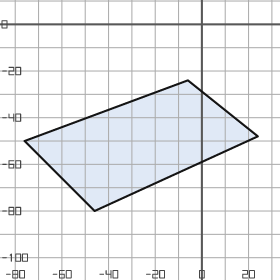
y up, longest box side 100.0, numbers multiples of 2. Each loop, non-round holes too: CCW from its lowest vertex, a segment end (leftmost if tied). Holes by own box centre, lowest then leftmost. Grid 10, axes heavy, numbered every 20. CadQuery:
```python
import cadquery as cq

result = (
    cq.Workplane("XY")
    .moveTo(-46.0, -80.0)
    .lineTo(24.0, -48.0)
    .lineTo(-6.0, -24.0)
    .lineTo(-76.0, -50.0)
    .close()
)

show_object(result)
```